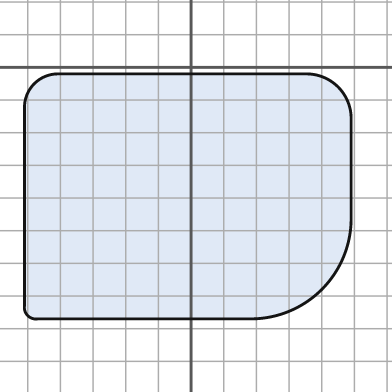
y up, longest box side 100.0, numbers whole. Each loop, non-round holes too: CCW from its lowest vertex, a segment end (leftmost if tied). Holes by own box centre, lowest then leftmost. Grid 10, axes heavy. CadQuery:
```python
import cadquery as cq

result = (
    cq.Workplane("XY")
    .moveTo(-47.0, -77.0)
    .lineTo(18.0, -77.0)
    .threePointArc((40.0, -68.0), (49.0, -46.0))
    .lineTo(49.0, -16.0)
    .threePointArc((45.0, -6.0), (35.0, -2.0))
    .lineTo(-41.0, -2.0)
    .threePointArc((-48.0, -5.0), (-51.0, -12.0))
    .lineTo(-51.0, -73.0)
    .threePointArc((-50.0, -76.0), (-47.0, -77.0))
    .close()
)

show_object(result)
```